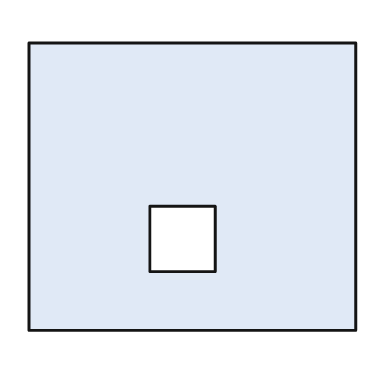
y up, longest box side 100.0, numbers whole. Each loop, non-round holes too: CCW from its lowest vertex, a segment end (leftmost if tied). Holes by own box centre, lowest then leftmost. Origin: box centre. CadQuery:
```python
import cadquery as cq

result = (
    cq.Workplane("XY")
    .moveTo(-50.0, -44.0)
    .lineTo(50.0, -44.0)
    .lineTo(50.0, 44.0)
    .lineTo(-50.0, 44.0)
    .close()
    .moveTo(-13.0, -26.0)
    .lineTo(7.0, -26.0)
    .lineTo(7.0, -6.0)
    .lineTo(-13.0, -6.0)
    .close()
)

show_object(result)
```